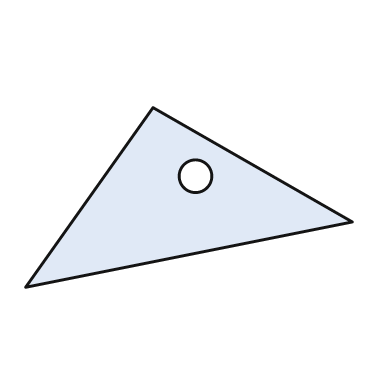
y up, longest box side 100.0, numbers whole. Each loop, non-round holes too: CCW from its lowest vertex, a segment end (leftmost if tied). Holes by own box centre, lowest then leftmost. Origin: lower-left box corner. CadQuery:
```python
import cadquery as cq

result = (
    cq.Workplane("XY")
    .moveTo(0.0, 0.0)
    .lineTo(100.0, 20.0)
    .lineTo(39.0, 55.0)
    .close()
    .moveTo(52.0, 34.0)
    .circle(5.0)
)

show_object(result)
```